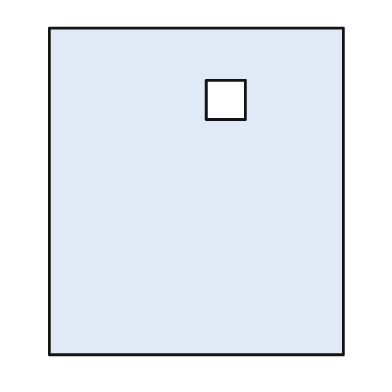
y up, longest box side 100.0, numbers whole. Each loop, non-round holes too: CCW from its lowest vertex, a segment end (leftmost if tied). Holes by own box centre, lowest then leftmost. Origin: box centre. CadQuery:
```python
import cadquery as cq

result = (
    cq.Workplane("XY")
    .moveTo(-45.0, -50.0)
    .lineTo(45.0, -50.0)
    .lineTo(45.0, 50.0)
    .lineTo(-45.0, 50.0)
    .close()
    .moveTo(3.0, 22.0)
    .lineTo(15.0, 22.0)
    .lineTo(15.0, 34.0)
    .lineTo(3.0, 34.0)
    .close()
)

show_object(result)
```